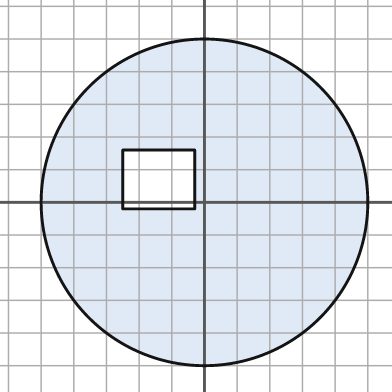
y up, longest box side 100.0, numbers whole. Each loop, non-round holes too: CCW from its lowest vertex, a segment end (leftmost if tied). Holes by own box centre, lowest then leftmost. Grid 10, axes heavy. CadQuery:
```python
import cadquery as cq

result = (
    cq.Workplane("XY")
    .moveTo(0.0, 0.0)
    .circle(50.0)
    .moveTo(-25.0, -2.0)
    .lineTo(-3.0, -2.0)
    .lineTo(-3.0, 16.0)
    .lineTo(-25.0, 16.0)
    .close()
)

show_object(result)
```